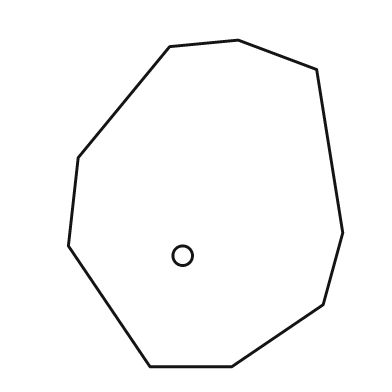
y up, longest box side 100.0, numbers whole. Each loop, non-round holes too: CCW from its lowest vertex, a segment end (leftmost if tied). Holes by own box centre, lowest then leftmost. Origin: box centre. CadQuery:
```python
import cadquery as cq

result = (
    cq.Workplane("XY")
    .moveTo(-17.0, -50.0)
    .lineTo(8.0, -50.0)
    .lineTo(36.0, -31.0)
    .lineTo(42.0, -9.0)
    .lineTo(34.0, 41.0)
    .lineTo(10.0, 50.0)
    .lineTo(-11.0, 48.0)
    .lineTo(-39.0, 14.0)
    .lineTo(-42.0, -13.0)
    .close()
    .moveTo(-7.0, -16.0)
    .circle(3.0)
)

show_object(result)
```